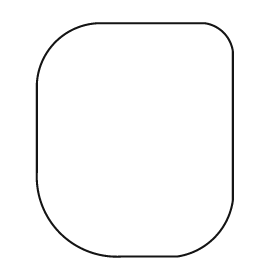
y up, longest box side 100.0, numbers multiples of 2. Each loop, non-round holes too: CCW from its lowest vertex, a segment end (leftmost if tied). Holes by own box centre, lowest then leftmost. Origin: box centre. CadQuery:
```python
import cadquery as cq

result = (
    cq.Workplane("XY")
    .moveTo(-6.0, -50.0)
    .lineTo(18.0, -50.0)
    .threePointArc((34.0, -42.0), (42.0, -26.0))
    .lineTo(42.0, 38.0)
    .threePointArc((38.0, 46.0), (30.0, 50.0))
    .lineTo(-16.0, 50.0)
    .threePointArc((-34.0, 42.0), (-42.0, 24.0))
    .lineTo(-42.0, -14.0)
    .threePointArc((-32.0, -40.0), (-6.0, -50.0))
    .close()
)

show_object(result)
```